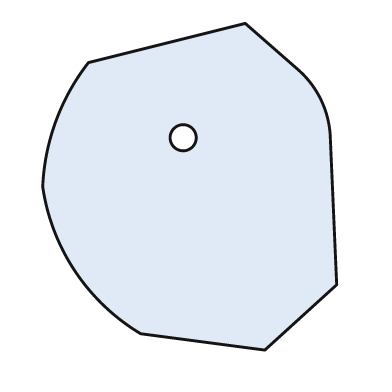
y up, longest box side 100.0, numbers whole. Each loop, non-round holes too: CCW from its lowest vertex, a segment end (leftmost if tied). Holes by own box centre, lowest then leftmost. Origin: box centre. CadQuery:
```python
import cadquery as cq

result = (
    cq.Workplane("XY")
    .moveTo(23.0, -50.0)
    .lineTo(45.0, -30.0)
    .lineTo(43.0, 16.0)
    .threePointArc((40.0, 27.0), (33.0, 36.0))
    .lineTo(17.0, 50.0)
    .lineTo(-31.0, 38.0)
    .threePointArc((-41.0, 20.0), (-45.0, 0.0))
    .threePointArc((-35.0, -26.0), (-15.0, -45.0))
    .close()
    .moveTo(-2.0, 15.0)
    .circle(4.0)
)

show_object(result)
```